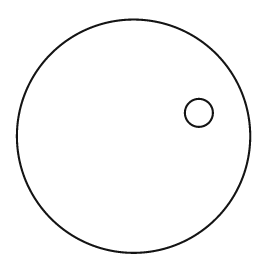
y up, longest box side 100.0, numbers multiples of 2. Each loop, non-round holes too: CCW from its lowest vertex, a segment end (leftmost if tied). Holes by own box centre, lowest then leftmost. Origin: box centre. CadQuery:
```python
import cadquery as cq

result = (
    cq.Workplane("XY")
    .moveTo(0.0, 0.0)
    .circle(50.0)
    .moveTo(28.0, 10.0)
    .circle(6.0)
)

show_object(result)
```